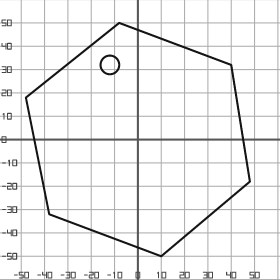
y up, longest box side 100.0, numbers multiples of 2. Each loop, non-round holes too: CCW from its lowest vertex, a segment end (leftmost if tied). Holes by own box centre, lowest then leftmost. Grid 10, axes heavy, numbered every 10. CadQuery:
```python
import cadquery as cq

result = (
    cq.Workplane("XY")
    .moveTo(10.0, -50.0)
    .lineTo(48.0, -18.0)
    .lineTo(40.0, 32.0)
    .lineTo(-8.0, 50.0)
    .lineTo(-48.0, 18.0)
    .lineTo(-38.0, -32.0)
    .close()
    .moveTo(-12.0, 32.0)
    .circle(4.0)
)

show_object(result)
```